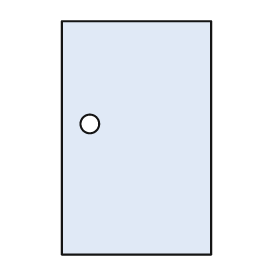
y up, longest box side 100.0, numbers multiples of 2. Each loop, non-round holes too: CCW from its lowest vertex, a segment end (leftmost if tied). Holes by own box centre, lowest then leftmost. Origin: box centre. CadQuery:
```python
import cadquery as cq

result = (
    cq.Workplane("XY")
    .moveTo(-32.0, -50.0)
    .lineTo(32.0, -50.0)
    .lineTo(32.0, 50.0)
    .lineTo(-32.0, 50.0)
    .close()
    .moveTo(-20.0, 6.0)
    .circle(4.0)
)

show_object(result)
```